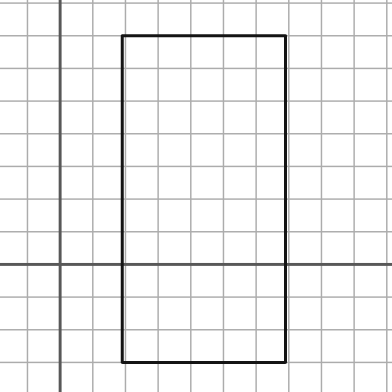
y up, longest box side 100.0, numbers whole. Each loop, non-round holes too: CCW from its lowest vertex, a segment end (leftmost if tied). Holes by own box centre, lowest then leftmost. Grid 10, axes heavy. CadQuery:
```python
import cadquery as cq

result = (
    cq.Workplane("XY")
    .moveTo(19.0, -30.0)
    .lineTo(69.0, -30.0)
    .lineTo(69.0, 70.0)
    .lineTo(19.0, 70.0)
    .close()
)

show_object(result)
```